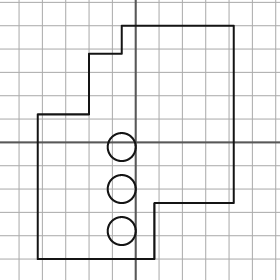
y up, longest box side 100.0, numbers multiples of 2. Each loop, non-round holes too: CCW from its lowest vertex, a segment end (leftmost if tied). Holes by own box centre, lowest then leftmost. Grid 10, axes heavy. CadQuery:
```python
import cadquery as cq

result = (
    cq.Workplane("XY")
    .moveTo(-42.0, -50.0)
    .lineTo(8.0, -50.0)
    .lineTo(8.0, -26.0)
    .lineTo(42.0, -26.0)
    .lineTo(42.0, 50.0)
    .lineTo(-6.0, 50.0)
    .lineTo(-6.0, 38.0)
    .lineTo(-20.0, 38.0)
    .lineTo(-20.0, 12.0)
    .lineTo(-42.0, 12.0)
    .close()
    .moveTo(-6.0, -38.0)
    .circle(6.0)
    .moveTo(-6.0, -20.0)
    .circle(6.0)
    .moveTo(-6.0, -2.0)
    .circle(6.0)
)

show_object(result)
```